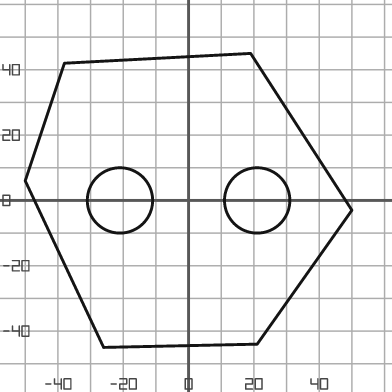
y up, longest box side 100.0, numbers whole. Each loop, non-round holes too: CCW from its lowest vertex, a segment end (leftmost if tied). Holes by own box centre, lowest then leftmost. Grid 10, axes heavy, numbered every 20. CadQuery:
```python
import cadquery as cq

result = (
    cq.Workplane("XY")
    .moveTo(-26.0, -45.0)
    .lineTo(21.0, -44.0)
    .lineTo(50.0, -3.0)
    .lineTo(19.0, 45.0)
    .lineTo(-38.0, 42.0)
    .lineTo(-50.0, 6.0)
    .close()
    .moveTo(-21.0, 0.0)
    .circle(10.0)
    .moveTo(21.0, 0.0)
    .circle(10.0)
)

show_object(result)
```